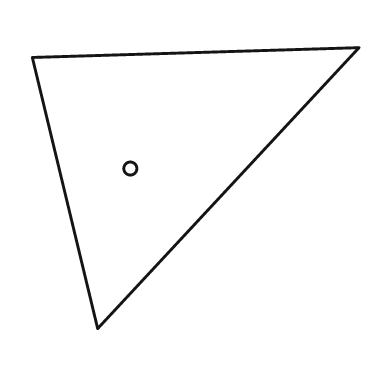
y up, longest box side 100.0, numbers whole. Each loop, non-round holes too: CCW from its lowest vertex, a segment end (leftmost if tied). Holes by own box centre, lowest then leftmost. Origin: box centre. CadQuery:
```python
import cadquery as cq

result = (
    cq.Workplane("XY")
    .moveTo(-30.0, -43.0)
    .lineTo(50.0, 43.0)
    .lineTo(-50.0, 40.0)
    .close()
    .moveTo(-20.0, 6.0)
    .circle(2.0)
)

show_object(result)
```